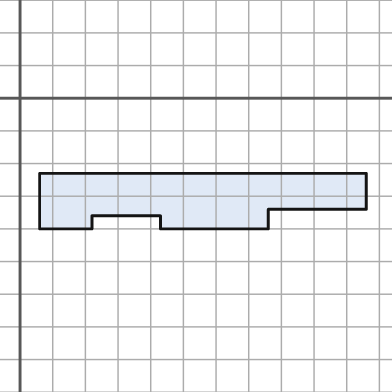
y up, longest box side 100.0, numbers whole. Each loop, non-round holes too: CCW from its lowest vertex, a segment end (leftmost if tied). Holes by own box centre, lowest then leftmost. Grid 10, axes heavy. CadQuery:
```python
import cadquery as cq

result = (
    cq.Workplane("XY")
    .moveTo(6.0, -40.0)
    .lineTo(22.0, -40.0)
    .lineTo(22.0, -36.0)
    .lineTo(43.0, -36.0)
    .lineTo(43.0, -40.0)
    .lineTo(76.0, -40.0)
    .lineTo(76.0, -34.0)
    .lineTo(106.0, -34.0)
    .lineTo(106.0, -23.0)
    .lineTo(6.0, -23.0)
    .close()
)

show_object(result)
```